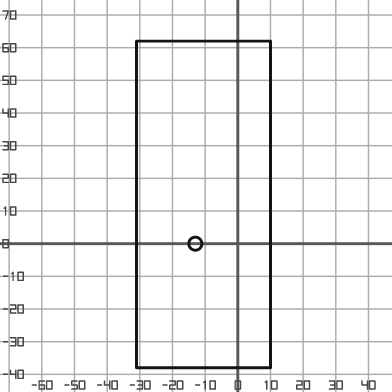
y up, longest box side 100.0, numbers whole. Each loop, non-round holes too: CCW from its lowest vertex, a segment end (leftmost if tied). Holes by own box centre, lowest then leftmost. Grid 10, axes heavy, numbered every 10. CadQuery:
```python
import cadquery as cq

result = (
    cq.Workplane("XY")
    .moveTo(-31.0, -38.0)
    .lineTo(10.0, -38.0)
    .lineTo(10.0, 62.0)
    .lineTo(-31.0, 62.0)
    .close()
    .moveTo(-13.0, 0.0)
    .circle(2.0)
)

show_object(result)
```